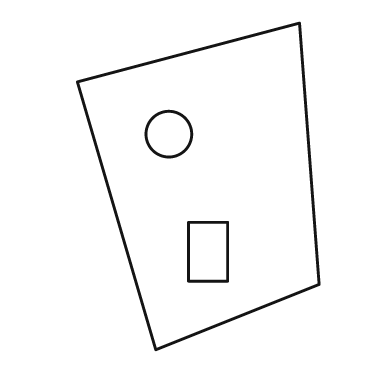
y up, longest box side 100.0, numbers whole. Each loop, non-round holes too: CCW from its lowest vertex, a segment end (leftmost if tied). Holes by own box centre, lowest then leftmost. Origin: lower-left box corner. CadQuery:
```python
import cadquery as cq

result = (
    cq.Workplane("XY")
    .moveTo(24.0, 0.0)
    .lineTo(74.0, 20.0)
    .lineTo(68.0, 100.0)
    .lineTo(0.0, 82.0)
    .close()
    .moveTo(34.0, 21.0)
    .lineTo(46.0, 21.0)
    .lineTo(46.0, 39.0)
    .lineTo(34.0, 39.0)
    .close()
    .moveTo(28.0, 66.0)
    .circle(7.0)
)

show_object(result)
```